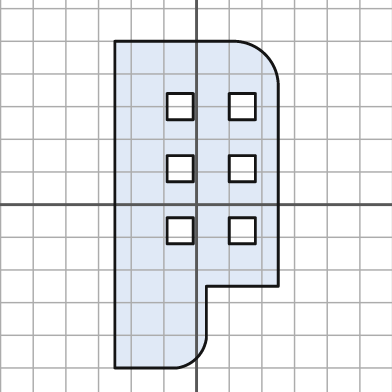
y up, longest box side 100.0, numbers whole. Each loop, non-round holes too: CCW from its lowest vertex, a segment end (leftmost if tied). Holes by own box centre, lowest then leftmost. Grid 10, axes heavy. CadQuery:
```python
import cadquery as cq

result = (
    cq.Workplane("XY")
    .moveTo(-25.0, -50.0)
    .lineTo(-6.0, -50.0)
    .threePointArc((0.0, -47.0), (3.0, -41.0))
    .lineTo(3.0, -25.0)
    .lineTo(25.0, -25.0)
    .lineTo(25.0, 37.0)
    .threePointArc((21.0, 46.0), (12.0, 50.0))
    .lineTo(-25.0, 50.0)
    .close()
    .moveTo(-9.0, -12.0)
    .lineTo(-1.0, -12.0)
    .lineTo(-1.0, -4.0)
    .lineTo(-9.0, -4.0)
    .close()
    .moveTo(10.0, -12.0)
    .lineTo(18.0, -12.0)
    .lineTo(18.0, -4.0)
    .lineTo(10.0, -4.0)
    .close()
    .moveTo(-9.0, 7.0)
    .lineTo(-1.0, 7.0)
    .lineTo(-1.0, 15.0)
    .lineTo(-9.0, 15.0)
    .close()
    .moveTo(10.0, 7.0)
    .lineTo(18.0, 7.0)
    .lineTo(18.0, 15.0)
    .lineTo(10.0, 15.0)
    .close()
    .moveTo(-9.0, 26.0)
    .lineTo(-1.0, 26.0)
    .lineTo(-1.0, 34.0)
    .lineTo(-9.0, 34.0)
    .close()
    .moveTo(10.0, 26.0)
    .lineTo(18.0, 26.0)
    .lineTo(18.0, 34.0)
    .lineTo(10.0, 34.0)
    .close()
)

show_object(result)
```